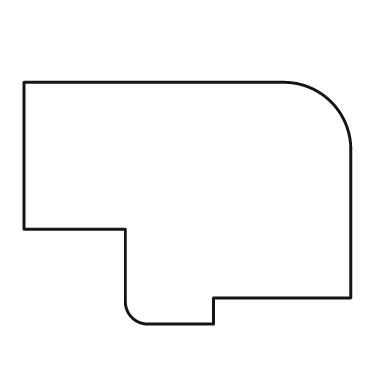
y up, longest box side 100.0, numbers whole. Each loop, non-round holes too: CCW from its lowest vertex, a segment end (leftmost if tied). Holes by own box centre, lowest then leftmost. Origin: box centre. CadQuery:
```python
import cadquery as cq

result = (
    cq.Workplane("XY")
    .moveTo(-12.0, -37.0)
    .lineTo(8.0, -37.0)
    .lineTo(8.0, -29.0)
    .lineTo(50.0, -29.0)
    .lineTo(50.0, 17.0)
    .threePointArc((44.0, 31.0), (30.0, 37.0))
    .lineTo(-50.0, 37.0)
    .lineTo(-50.0, -8.0)
    .lineTo(-19.0, -8.0)
    .lineTo(-19.0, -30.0)
    .threePointArc((-17.0, -35.0), (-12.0, -37.0))
    .close()
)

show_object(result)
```